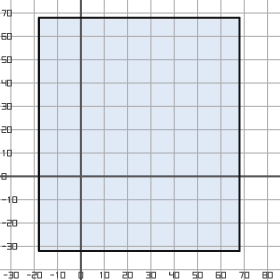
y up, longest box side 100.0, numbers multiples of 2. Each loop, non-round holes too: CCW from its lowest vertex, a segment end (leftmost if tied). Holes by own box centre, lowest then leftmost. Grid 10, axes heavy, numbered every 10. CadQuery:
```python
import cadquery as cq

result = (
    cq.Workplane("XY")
    .moveTo(-18.0, -32.0)
    .lineTo(68.0, -32.0)
    .lineTo(68.0, 68.0)
    .lineTo(-18.0, 68.0)
    .close()
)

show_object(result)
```